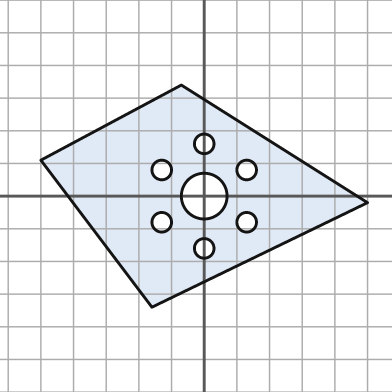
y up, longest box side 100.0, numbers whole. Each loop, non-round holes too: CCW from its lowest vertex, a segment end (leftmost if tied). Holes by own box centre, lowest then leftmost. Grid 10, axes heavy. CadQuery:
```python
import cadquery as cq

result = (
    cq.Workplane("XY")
    .moveTo(-16.0, -34.0)
    .lineTo(50.0, -2.0)
    .lineTo(-7.0, 34.0)
    .lineTo(-50.0, 11.0)
    .close()
    .moveTo(0.0, -16.0)
    .circle(3.0)
    .moveTo(-13.0, -8.0)
    .circle(3.0)
    .moveTo(13.0, -8.0)
    .circle(3.0)
    .moveTo(0.0, 0.0)
    .circle(7.0)
    .moveTo(-13.0, 8.0)
    .circle(3.0)
    .moveTo(13.0, 8.0)
    .circle(3.0)
    .moveTo(0.0, 16.0)
    .circle(3.0)
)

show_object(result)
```